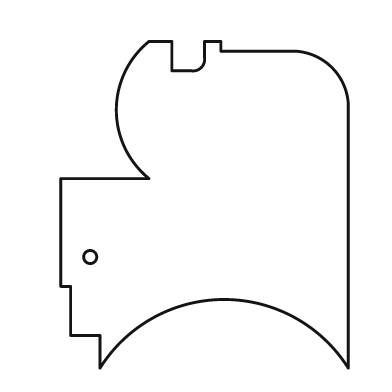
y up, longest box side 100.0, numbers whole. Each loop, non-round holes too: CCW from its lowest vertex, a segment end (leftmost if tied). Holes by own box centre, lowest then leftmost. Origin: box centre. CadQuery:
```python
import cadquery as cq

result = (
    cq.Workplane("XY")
    .moveTo(-32.0, -50.0)
    .threePointArc((6.0, -29.0), (44.0, -50.0))
    .lineTo(44.0, 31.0)
    .threePointArc((39.0, 42.0), (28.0, 47.0))
    .lineTo(5.0, 47.0)
    .lineTo(5.0, 50.0)
    .lineTo(0.0, 50.0)
    .lineTo(0.0, 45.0)
    .threePointArc((-1.0, 42.0), (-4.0, 41.0))
    .lineTo(-10.0, 41.0)
    .lineTo(-10.0, 50.0)
    .lineTo(-17.0, 50.0)
    .threePointArc((-27.0, 29.0), (-17.0, 8.0))
    .lineTo(-44.0, 8.0)
    .lineTo(-44.0, -25.0)
    .lineTo(-41.0, -25.0)
    .lineTo(-41.0, -40.0)
    .lineTo(-32.0, -40.0)
    .close()
    .moveTo(-35.0, -16.0)
    .circle(2.0)
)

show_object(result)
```